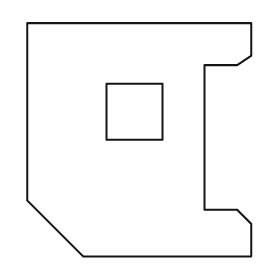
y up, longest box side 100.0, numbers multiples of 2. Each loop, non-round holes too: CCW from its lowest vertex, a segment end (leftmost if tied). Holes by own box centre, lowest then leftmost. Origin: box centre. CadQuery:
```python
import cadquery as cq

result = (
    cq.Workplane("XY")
    .moveTo(-24.0, -50.0)
    .lineTo(48.0, -50.0)
    .lineTo(48.0, -36.0)
    .lineTo(42.0, -30.0)
    .lineTo(28.0, -30.0)
    .lineTo(28.0, 32.0)
    .lineTo(42.0, 32.0)
    .lineTo(48.0, 36.0)
    .lineTo(48.0, 50.0)
    .lineTo(-48.0, 50.0)
    .lineTo(-48.0, -26.0)
    .close()
    .moveTo(-14.0, 0.0)
    .lineTo(10.0, 0.0)
    .lineTo(10.0, 24.0)
    .lineTo(-14.0, 24.0)
    .close()
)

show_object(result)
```